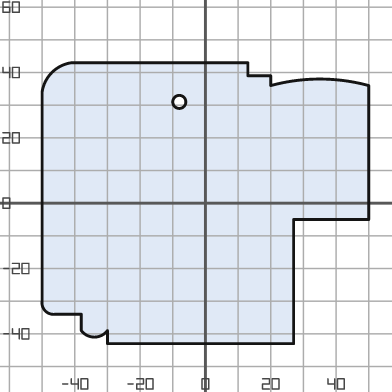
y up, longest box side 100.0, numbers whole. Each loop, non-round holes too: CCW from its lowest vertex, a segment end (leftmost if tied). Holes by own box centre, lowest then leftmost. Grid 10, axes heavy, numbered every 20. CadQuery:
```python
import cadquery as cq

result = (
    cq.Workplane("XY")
    .moveTo(-30.0, -43.0)
    .lineTo(27.0, -43.0)
    .lineTo(27.0, -5.0)
    .lineTo(50.0, -5.0)
    .lineTo(50.0, 36.0)
    .threePointArc((35.0, 38.0), (20.0, 36.0))
    .lineTo(20.0, 39.0)
    .lineTo(13.0, 39.0)
    .lineTo(13.0, 43.0)
    .lineTo(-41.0, 43.0)
    .threePointArc((-47.0, 40.0), (-50.0, 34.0))
    .lineTo(-50.0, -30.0)
    .threePointArc((-49.0, -33.0), (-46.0, -34.0))
    .lineTo(-38.0, -34.0)
    .lineTo(-38.0, -39.0)
    .threePointArc((-34.0, -41.0), (-30.0, -39.0))
    .close()
    .moveTo(-8.0, 31.0)
    .circle(2.0)
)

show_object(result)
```